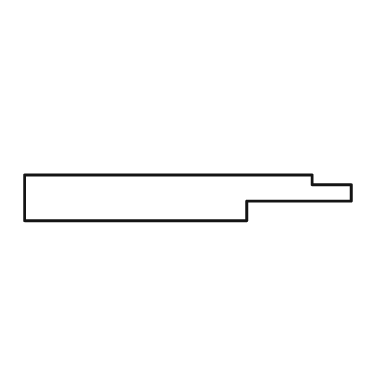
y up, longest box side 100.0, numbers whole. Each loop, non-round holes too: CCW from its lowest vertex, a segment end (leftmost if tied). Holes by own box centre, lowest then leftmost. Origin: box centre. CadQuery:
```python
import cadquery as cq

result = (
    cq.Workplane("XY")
    .moveTo(-50.0, -7.0)
    .lineTo(18.0, -7.0)
    .lineTo(18.0, -1.0)
    .lineTo(50.0, -1.0)
    .lineTo(50.0, 4.0)
    .lineTo(38.0, 4.0)
    .lineTo(38.0, 7.0)
    .lineTo(-50.0, 7.0)
    .close()
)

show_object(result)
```